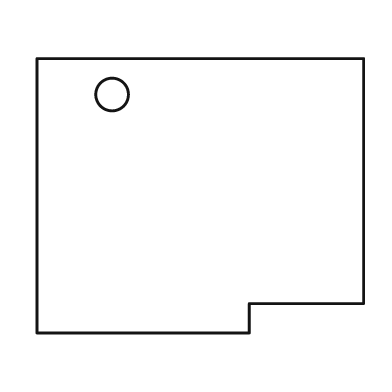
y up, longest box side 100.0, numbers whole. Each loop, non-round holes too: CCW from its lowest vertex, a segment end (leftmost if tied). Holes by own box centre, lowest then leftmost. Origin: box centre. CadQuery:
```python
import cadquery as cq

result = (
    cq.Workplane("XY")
    .moveTo(-50.0, -42.0)
    .lineTo(15.0, -42.0)
    .lineTo(15.0, -33.0)
    .lineTo(50.0, -33.0)
    .lineTo(50.0, 42.0)
    .lineTo(-50.0, 42.0)
    .close()
    .moveTo(-27.0, 31.0)
    .circle(5.0)
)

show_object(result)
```